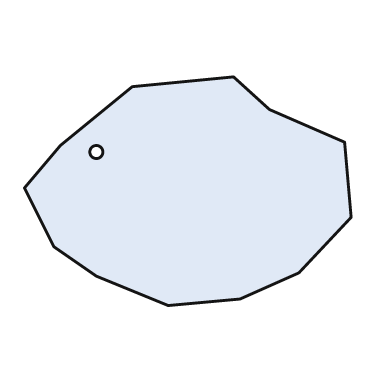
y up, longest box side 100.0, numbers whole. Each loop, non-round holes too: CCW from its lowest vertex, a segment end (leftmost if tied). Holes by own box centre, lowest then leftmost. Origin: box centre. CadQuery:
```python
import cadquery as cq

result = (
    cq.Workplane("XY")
    .moveTo(-6.0, -35.0)
    .lineTo(16.0, -33.0)
    .lineTo(34.0, -25.0)
    .lineTo(50.0, -8.0)
    .lineTo(48.0, 15.0)
    .lineTo(25.0, 25.0)
    .lineTo(14.0, 35.0)
    .lineTo(-17.0, 32.0)
    .lineTo(-39.0, 14.0)
    .lineTo(-50.0, 1.0)
    .lineTo(-41.0, -17.0)
    .lineTo(-28.0, -26.0)
    .close()
    .moveTo(-28.0, 12.0)
    .circle(2.0)
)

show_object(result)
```